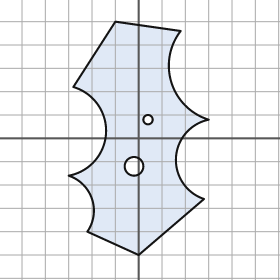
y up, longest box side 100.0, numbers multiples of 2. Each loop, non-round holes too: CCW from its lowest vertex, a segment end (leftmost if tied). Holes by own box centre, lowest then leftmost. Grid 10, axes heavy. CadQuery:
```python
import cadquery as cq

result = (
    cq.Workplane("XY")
    .moveTo(0.0, -50.0)
    .lineTo(28.0, -26.0)
    .threePointArc((16.0, -8.0), (30.0, 8.0))
    .threePointArc((14.0, 24.0), (18.0, 46.0))
    .lineTo(-10.0, 50.0)
    .lineTo(-28.0, 22.0)
    .threePointArc((-14.0, 2.0), (-30.0, -16.0))
    .threePointArc((-20.0, -26.0), (-22.0, -40.0))
    .close()
    .moveTo(-2.0, -12.0)
    .circle(4.0)
    .moveTo(4.0, 8.0)
    .circle(2.0)
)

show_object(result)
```